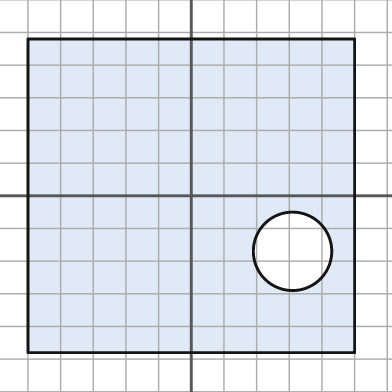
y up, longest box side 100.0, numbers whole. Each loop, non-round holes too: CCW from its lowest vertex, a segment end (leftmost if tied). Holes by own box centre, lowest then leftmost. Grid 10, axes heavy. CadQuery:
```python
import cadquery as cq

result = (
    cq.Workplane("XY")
    .moveTo(-50.0, -48.0)
    .lineTo(50.0, -48.0)
    .lineTo(50.0, 48.0)
    .lineTo(-50.0, 48.0)
    .close()
    .moveTo(31.0, -17.0)
    .circle(12.0)
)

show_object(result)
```